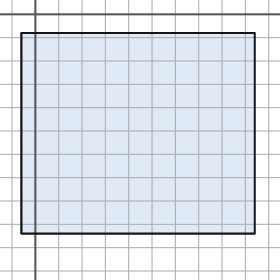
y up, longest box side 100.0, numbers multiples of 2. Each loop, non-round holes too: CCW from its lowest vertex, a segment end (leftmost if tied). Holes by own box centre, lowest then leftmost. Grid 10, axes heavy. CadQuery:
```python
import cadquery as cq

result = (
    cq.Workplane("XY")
    .moveTo(-6.0, -94.0)
    .lineTo(94.0, -94.0)
    .lineTo(94.0, -8.0)
    .lineTo(-6.0, -8.0)
    .close()
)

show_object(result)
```